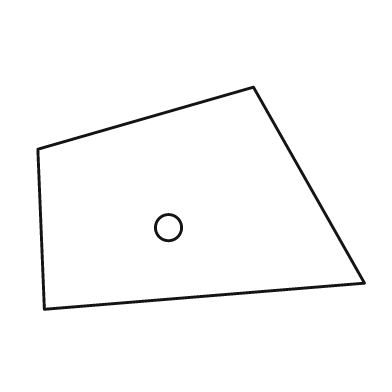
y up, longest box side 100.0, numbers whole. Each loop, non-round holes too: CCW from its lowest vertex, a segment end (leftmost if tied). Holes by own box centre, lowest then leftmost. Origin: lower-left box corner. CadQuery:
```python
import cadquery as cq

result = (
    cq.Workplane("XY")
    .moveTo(2.0, 0.0)
    .lineTo(100.0, 8.0)
    .lineTo(66.0, 68.0)
    .lineTo(0.0, 49.0)
    .close()
    .moveTo(40.0, 25.0)
    .circle(4.0)
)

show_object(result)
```